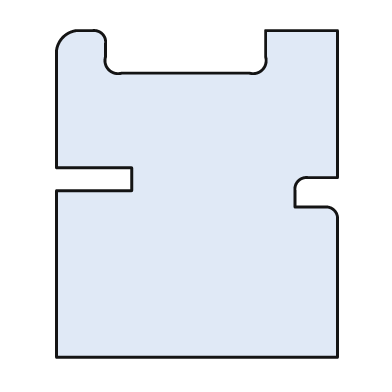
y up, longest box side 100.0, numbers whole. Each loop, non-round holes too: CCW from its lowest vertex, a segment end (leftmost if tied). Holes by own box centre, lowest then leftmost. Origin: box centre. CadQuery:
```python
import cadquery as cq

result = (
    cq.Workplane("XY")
    .moveTo(-43.0, -50.0)
    .lineTo(43.0, -50.0)
    .lineTo(43.0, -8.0)
    .threePointArc((42.0, -5.0), (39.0, -4.0))
    .lineTo(30.0, -4.0)
    .lineTo(30.0, 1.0)
    .threePointArc((31.0, 4.0), (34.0, 5.0))
    .lineTo(43.0, 5.0)
    .lineTo(43.0, 50.0)
    .lineTo(21.0, 50.0)
    .lineTo(21.0, 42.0)
    .threePointArc((20.0, 38.0), (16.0, 37.0))
    .lineTo(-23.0, 37.0)
    .threePointArc((-27.0, 38.0), (-28.0, 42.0))
    .lineTo(-28.0, 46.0)
    .threePointArc((-29.0, 49.0), (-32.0, 50.0))
    .lineTo(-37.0, 50.0)
    .threePointArc((-41.0, 48.0), (-43.0, 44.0))
    .lineTo(-43.0, 8.0)
    .lineTo(-20.0, 8.0)
    .lineTo(-20.0, 1.0)
    .lineTo(-43.0, 1.0)
    .close()
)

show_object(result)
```